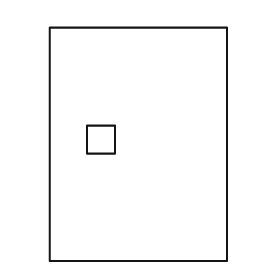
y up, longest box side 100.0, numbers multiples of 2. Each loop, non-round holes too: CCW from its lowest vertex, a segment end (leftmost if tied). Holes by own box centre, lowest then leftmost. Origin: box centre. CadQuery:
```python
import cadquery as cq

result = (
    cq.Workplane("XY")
    .moveTo(-38.0, -50.0)
    .lineTo(38.0, -50.0)
    .lineTo(38.0, 50.0)
    .lineTo(-38.0, 50.0)
    .close()
    .moveTo(-22.0, -4.0)
    .lineTo(-10.0, -4.0)
    .lineTo(-10.0, 8.0)
    .lineTo(-22.0, 8.0)
    .close()
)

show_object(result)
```